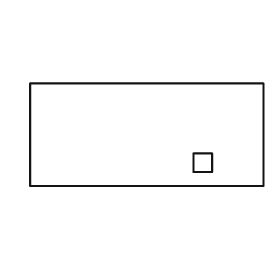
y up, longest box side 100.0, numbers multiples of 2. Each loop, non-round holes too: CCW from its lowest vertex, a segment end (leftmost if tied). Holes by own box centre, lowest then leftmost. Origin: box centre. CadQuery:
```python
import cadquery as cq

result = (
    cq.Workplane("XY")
    .moveTo(-50.0, -22.0)
    .lineTo(50.0, -22.0)
    .lineTo(50.0, 22.0)
    .lineTo(-50.0, 22.0)
    .close()
    .moveTo(20.0, -16.0)
    .lineTo(28.0, -16.0)
    .lineTo(28.0, -8.0)
    .lineTo(20.0, -8.0)
    .close()
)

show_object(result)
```